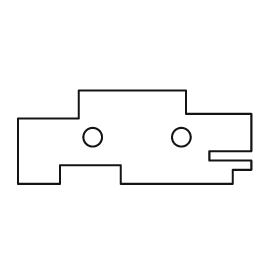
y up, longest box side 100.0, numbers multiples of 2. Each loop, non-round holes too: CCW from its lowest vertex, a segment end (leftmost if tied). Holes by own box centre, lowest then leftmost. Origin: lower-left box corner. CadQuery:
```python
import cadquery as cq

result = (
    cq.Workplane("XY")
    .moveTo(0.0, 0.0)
    .lineTo(18.0, 0.0)
    .lineTo(18.0, 8.0)
    .lineTo(44.0, 8.0)
    .lineTo(44.0, 0.0)
    .lineTo(92.0, 0.0)
    .lineTo(92.0, 6.0)
    .lineTo(100.0, 6.0)
    .lineTo(100.0, 10.0)
    .lineTo(82.0, 10.0)
    .lineTo(82.0, 14.0)
    .lineTo(100.0, 14.0)
    .lineTo(100.0, 30.0)
    .lineTo(72.0, 30.0)
    .lineTo(72.0, 40.0)
    .lineTo(26.0, 40.0)
    .lineTo(26.0, 28.0)
    .lineTo(0.0, 28.0)
    .close()
    .moveTo(32.0, 20.0)
    .circle(4.0)
    .moveTo(70.0, 20.0)
    .circle(4.0)
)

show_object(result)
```